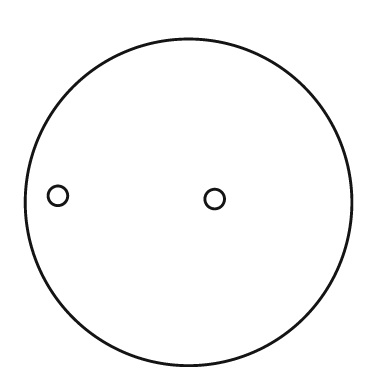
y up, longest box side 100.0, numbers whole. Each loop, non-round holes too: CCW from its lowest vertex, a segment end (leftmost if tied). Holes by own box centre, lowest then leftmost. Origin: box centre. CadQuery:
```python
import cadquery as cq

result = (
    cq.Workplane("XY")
    .moveTo(0.0, 0.0)
    .circle(50.0)
    .moveTo(8.0, 1.0)
    .circle(3.0)
    .moveTo(-40.0, 2.0)
    .circle(3.0)
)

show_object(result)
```